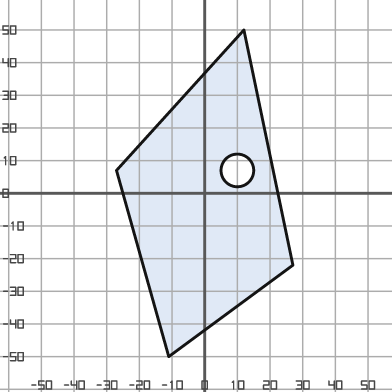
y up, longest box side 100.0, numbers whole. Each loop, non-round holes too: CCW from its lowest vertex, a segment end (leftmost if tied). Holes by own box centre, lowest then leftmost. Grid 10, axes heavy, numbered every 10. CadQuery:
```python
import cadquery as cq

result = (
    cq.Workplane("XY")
    .moveTo(-11.0, -50.0)
    .lineTo(27.0, -22.0)
    .lineTo(12.0, 50.0)
    .lineTo(-27.0, 7.0)
    .close()
    .moveTo(10.0, 7.0)
    .circle(5.0)
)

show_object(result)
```